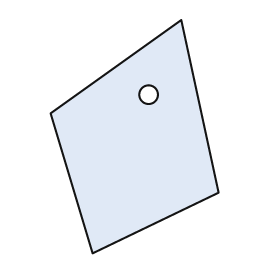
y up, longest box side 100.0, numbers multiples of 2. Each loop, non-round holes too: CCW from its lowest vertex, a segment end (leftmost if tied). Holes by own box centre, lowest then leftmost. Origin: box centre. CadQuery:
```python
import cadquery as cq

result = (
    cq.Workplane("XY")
    .moveTo(-18.0, -50.0)
    .lineTo(36.0, -24.0)
    .lineTo(20.0, 50.0)
    .lineTo(-36.0, 10.0)
    .close()
    .moveTo(6.0, 18.0)
    .circle(4.0)
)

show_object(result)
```